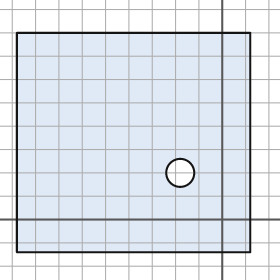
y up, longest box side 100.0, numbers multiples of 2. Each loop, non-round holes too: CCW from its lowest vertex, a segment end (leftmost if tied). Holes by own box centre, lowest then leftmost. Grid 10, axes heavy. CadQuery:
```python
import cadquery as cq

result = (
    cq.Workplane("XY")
    .moveTo(-88.0, -14.0)
    .lineTo(12.0, -14.0)
    .lineTo(12.0, 80.0)
    .lineTo(-88.0, 80.0)
    .close()
    .moveTo(-18.0, 20.0)
    .circle(6.0)
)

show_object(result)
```